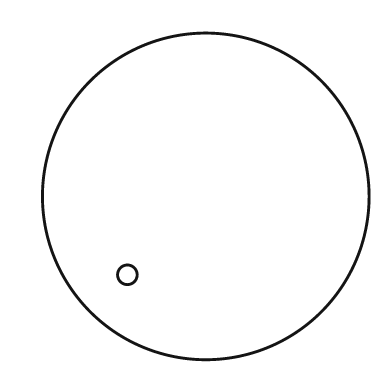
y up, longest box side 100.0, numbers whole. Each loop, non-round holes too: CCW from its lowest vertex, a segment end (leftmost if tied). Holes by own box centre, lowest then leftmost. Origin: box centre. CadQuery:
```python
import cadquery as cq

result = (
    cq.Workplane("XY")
    .moveTo(0.0, 0.0)
    .circle(50.0)
    .moveTo(-24.0, -24.0)
    .circle(3.0)
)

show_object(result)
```